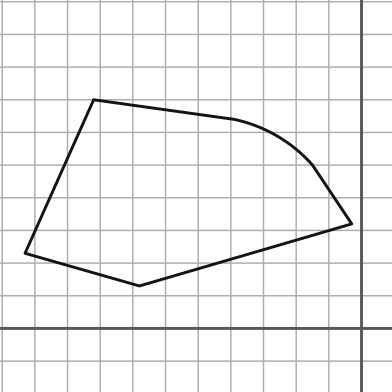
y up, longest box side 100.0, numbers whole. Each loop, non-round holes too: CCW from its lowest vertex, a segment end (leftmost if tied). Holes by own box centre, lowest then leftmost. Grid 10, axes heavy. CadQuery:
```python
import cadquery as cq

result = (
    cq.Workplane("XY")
    .moveTo(-68.0, 13.0)
    .lineTo(-3.0, 32.0)
    .lineTo(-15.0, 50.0)
    .threePointArc((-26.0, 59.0), (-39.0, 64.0))
    .lineTo(-82.0, 70.0)
    .lineTo(-103.0, 23.0)
    .close()
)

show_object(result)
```